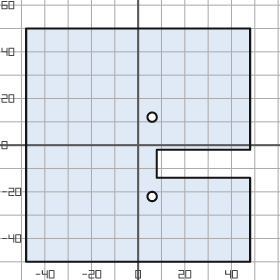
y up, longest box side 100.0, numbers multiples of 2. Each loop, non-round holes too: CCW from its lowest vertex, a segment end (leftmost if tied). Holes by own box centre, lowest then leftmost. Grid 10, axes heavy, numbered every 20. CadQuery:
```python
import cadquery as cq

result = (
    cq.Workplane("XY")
    .moveTo(-48.0, -50.0)
    .lineTo(48.0, -50.0)
    .lineTo(48.0, -14.0)
    .lineTo(8.0, -14.0)
    .lineTo(8.0, -2.0)
    .lineTo(48.0, -2.0)
    .lineTo(48.0, 50.0)
    .lineTo(-48.0, 50.0)
    .close()
    .moveTo(6.0, -22.0)
    .circle(2.0)
    .moveTo(6.0, 12.0)
    .circle(2.0)
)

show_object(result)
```